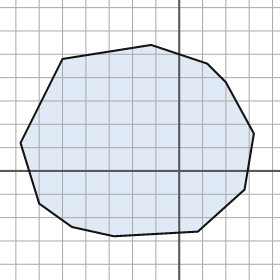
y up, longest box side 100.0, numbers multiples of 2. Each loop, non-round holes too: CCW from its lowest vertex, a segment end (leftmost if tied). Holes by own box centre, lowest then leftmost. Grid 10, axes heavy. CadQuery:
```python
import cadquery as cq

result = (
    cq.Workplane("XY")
    .moveTo(-28.0, -28.0)
    .lineTo(8.0, -26.0)
    .lineTo(28.0, -8.0)
    .lineTo(32.0, 16.0)
    .lineTo(20.0, 38.0)
    .lineTo(12.0, 46.0)
    .lineTo(-12.0, 54.0)
    .lineTo(-50.0, 48.0)
    .lineTo(-68.0, 12.0)
    .lineTo(-60.0, -14.0)
    .lineTo(-46.0, -24.0)
    .close()
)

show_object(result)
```